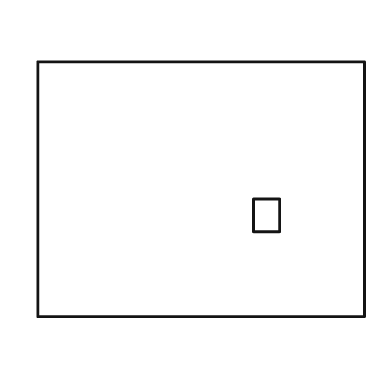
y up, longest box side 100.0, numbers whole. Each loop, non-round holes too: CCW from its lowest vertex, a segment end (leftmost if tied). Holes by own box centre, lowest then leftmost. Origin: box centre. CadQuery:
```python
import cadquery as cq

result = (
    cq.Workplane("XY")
    .moveTo(-50.0, -39.0)
    .lineTo(50.0, -39.0)
    .lineTo(50.0, 39.0)
    .lineTo(-50.0, 39.0)
    .close()
    .moveTo(16.0, -13.0)
    .lineTo(24.0, -13.0)
    .lineTo(24.0, -3.0)
    .lineTo(16.0, -3.0)
    .close()
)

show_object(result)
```